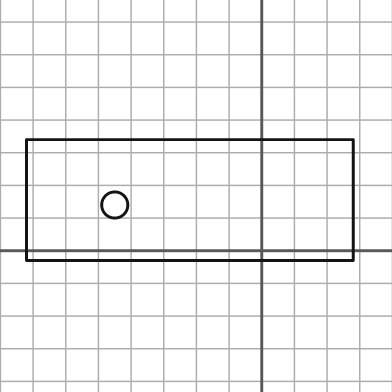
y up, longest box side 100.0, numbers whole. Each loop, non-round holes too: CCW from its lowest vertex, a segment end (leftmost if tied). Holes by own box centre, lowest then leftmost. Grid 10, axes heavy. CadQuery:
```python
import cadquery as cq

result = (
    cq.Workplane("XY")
    .moveTo(-72.0, -3.0)
    .lineTo(28.0, -3.0)
    .lineTo(28.0, 34.0)
    .lineTo(-72.0, 34.0)
    .close()
    .moveTo(-45.0, 14.0)
    .circle(4.0)
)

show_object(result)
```